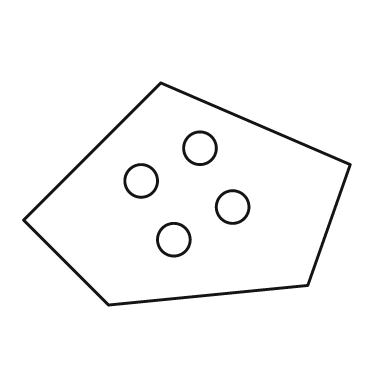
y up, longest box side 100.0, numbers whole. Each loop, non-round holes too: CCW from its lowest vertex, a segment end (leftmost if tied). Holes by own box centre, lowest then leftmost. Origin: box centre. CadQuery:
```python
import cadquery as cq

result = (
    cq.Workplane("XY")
    .moveTo(-24.0, -34.0)
    .lineTo(37.0, -28.0)
    .lineTo(50.0, 9.0)
    .lineTo(-8.0, 34.0)
    .lineTo(-50.0, -8.0)
    .close()
    .moveTo(-4.0, -14.0)
    .circle(5.0)
    .moveTo(14.0, -4.0)
    .circle(5.0)
    .moveTo(-14.0, 4.0)
    .circle(5.0)
    .moveTo(4.0, 14.0)
    .circle(5.0)
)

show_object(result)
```